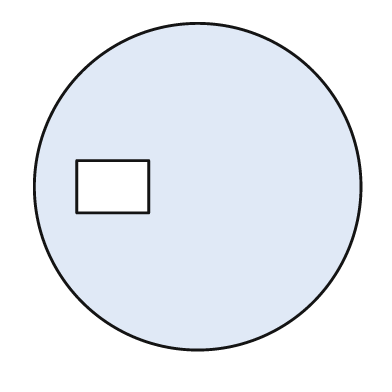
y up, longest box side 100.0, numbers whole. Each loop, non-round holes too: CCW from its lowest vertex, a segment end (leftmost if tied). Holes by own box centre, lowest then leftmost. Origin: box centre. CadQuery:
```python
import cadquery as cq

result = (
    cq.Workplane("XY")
    .moveTo(0.0, 0.0)
    .circle(50.0)
    .moveTo(-37.0, -8.0)
    .lineTo(-15.0, -8.0)
    .lineTo(-15.0, 8.0)
    .lineTo(-37.0, 8.0)
    .close()
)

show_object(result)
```